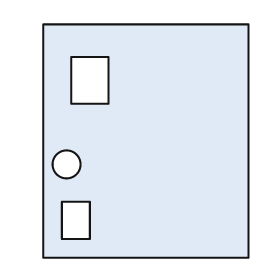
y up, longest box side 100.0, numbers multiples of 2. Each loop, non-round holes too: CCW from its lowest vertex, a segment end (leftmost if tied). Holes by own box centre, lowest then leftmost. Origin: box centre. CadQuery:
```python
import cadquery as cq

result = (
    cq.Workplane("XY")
    .moveTo(-44.0, -50.0)
    .lineTo(44.0, -50.0)
    .lineTo(44.0, 50.0)
    .lineTo(-44.0, 50.0)
    .close()
    .moveTo(-36.0, -42.0)
    .lineTo(-24.0, -42.0)
    .lineTo(-24.0, -26.0)
    .lineTo(-36.0, -26.0)
    .close()
    .moveTo(-34.0, -10.0)
    .circle(6.0)
    .moveTo(-32.0, 16.0)
    .lineTo(-16.0, 16.0)
    .lineTo(-16.0, 36.0)
    .lineTo(-32.0, 36.0)
    .close()
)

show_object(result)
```